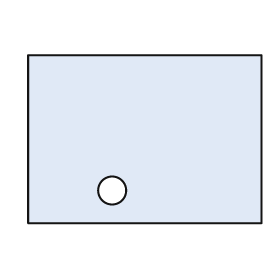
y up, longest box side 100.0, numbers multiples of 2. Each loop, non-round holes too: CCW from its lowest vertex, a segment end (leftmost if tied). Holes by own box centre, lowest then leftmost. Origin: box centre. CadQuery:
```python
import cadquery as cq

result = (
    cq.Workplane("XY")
    .moveTo(-50.0, -36.0)
    .lineTo(50.0, -36.0)
    .lineTo(50.0, 36.0)
    .lineTo(-50.0, 36.0)
    .close()
    .moveTo(-14.0, -22.0)
    .circle(6.0)
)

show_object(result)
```